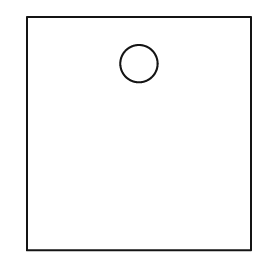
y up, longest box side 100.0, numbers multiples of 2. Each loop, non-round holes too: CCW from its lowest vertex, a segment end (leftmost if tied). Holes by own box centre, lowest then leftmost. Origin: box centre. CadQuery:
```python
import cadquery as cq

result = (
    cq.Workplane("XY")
    .moveTo(-48.0, -50.0)
    .lineTo(48.0, -50.0)
    .lineTo(48.0, 50.0)
    .lineTo(-48.0, 50.0)
    .close()
    .moveTo(0.0, 30.0)
    .circle(8.0)
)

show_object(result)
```